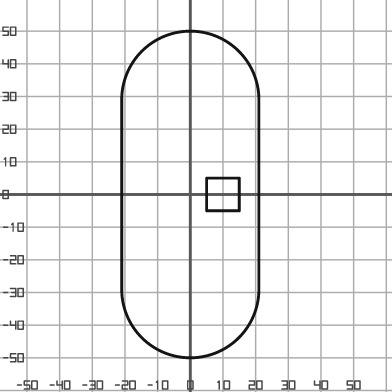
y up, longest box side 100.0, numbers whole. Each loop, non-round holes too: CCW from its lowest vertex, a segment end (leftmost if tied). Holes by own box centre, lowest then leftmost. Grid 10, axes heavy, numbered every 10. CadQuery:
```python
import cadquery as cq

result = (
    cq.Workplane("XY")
    .moveTo(-21.0, -29.0)
    .threePointArc((0.0, -50.0), (21.0, -29.0))
    .lineTo(21.0, 29.0)
    .threePointArc((0.0, 50.0), (-21.0, 29.0))
    .close()
    .moveTo(5.0, -5.0)
    .lineTo(15.0, -5.0)
    .lineTo(15.0, 5.0)
    .lineTo(5.0, 5.0)
    .close()
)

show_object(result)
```